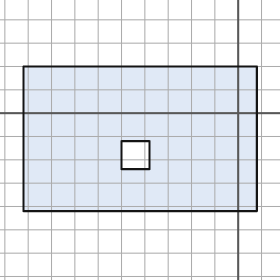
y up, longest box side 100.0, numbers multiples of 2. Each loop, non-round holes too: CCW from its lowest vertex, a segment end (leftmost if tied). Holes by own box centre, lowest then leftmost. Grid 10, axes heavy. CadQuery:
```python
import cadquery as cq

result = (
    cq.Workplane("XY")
    .moveTo(-92.0, -42.0)
    .lineTo(8.0, -42.0)
    .lineTo(8.0, 20.0)
    .lineTo(-92.0, 20.0)
    .close()
    .moveTo(-50.0, -24.0)
    .lineTo(-38.0, -24.0)
    .lineTo(-38.0, -12.0)
    .lineTo(-50.0, -12.0)
    .close()
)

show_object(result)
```